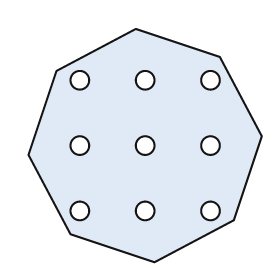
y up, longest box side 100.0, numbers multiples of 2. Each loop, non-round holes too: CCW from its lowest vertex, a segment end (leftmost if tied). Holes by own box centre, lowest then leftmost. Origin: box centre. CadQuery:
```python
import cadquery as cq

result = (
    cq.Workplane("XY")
    .moveTo(4.0, -50.0)
    .lineTo(38.0, -32.0)
    .lineTo(50.0, 4.0)
    .lineTo(32.0, 38.0)
    .lineTo(-4.0, 50.0)
    .lineTo(-38.0, 32.0)
    .lineTo(-50.0, -4.0)
    .lineTo(-32.0, -38.0)
    .close()
    .moveTo(-28.0, -28.0)
    .circle(4.0)
    .moveTo(0.0, -28.0)
    .circle(4.0)
    .moveTo(28.0, -28.0)
    .circle(4.0)
    .moveTo(-28.0, 0.0)
    .circle(4.0)
    .moveTo(0.0, 0.0)
    .circle(4.0)
    .moveTo(28.0, 0.0)
    .circle(4.0)
    .moveTo(-28.0, 28.0)
    .circle(4.0)
    .moveTo(0.0, 28.0)
    .circle(4.0)
    .moveTo(28.0, 28.0)
    .circle(4.0)
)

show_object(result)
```